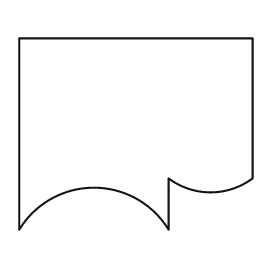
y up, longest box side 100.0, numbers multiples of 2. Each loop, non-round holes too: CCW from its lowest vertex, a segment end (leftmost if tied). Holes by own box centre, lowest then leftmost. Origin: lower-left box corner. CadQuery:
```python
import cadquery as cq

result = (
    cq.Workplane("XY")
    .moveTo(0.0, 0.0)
    .threePointArc((32.0, 18.0), (64.0, 0.0))
    .lineTo(64.0, 22.0)
    .threePointArc((82.0, 16.0), (100.0, 22.0))
    .lineTo(100.0, 82.0)
    .lineTo(0.0, 82.0)
    .close()
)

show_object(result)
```